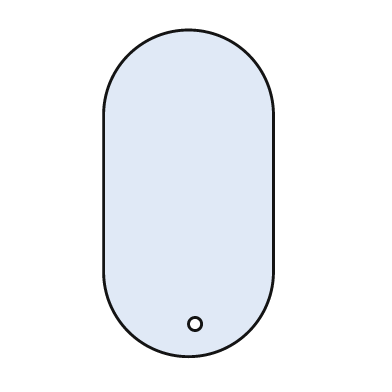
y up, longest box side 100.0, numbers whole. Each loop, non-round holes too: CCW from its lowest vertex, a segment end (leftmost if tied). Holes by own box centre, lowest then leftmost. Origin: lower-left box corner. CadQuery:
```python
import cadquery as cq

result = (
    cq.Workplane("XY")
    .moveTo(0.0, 26.0)
    .threePointArc((26.0, 0.0), (52.0, 26.0))
    .lineTo(52.0, 74.0)
    .threePointArc((26.0, 100.0), (0.0, 74.0))
    .close()
    .moveTo(28.0, 10.0)
    .circle(2.0)
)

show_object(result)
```